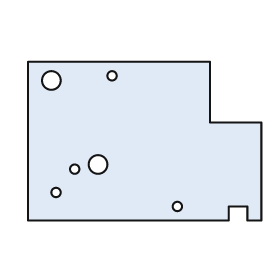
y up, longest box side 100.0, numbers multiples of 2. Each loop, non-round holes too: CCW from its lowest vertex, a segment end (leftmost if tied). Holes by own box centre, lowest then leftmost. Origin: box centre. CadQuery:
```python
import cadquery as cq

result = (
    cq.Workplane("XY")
    .moveTo(-50.0, -34.0)
    .lineTo(36.0, -34.0)
    .lineTo(36.0, -28.0)
    .lineTo(44.0, -28.0)
    .lineTo(44.0, -34.0)
    .lineTo(50.0, -34.0)
    .lineTo(50.0, 8.0)
    .lineTo(28.0, 8.0)
    .lineTo(28.0, 34.0)
    .lineTo(-50.0, 34.0)
    .close()
    .moveTo(14.0, -28.0)
    .circle(2.0)
    .moveTo(-38.0, -22.0)
    .circle(2.0)
    .moveTo(-30.0, -12.0)
    .circle(2.0)
    .moveTo(-20.0, -10.0)
    .circle(4.0)
    .moveTo(-40.0, 26.0)
    .circle(4.0)
    .moveTo(-14.0, 28.0)
    .circle(2.0)
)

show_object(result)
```